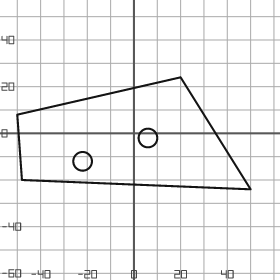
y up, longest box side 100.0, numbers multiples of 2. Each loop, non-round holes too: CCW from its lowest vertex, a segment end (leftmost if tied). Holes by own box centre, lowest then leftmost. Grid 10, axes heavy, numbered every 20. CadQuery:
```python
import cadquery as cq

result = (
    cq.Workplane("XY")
    .moveTo(50.0, -24.0)
    .lineTo(20.0, 24.0)
    .lineTo(-50.0, 8.0)
    .lineTo(-48.0, -20.0)
    .close()
    .moveTo(-22.0, -12.0)
    .circle(4.0)
    .moveTo(6.0, -2.0)
    .circle(4.0)
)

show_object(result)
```